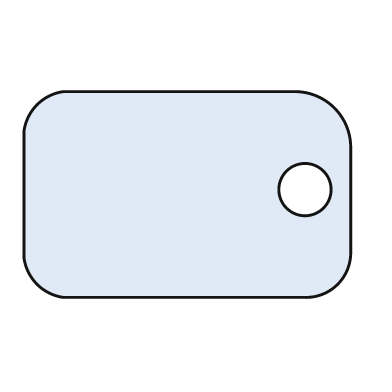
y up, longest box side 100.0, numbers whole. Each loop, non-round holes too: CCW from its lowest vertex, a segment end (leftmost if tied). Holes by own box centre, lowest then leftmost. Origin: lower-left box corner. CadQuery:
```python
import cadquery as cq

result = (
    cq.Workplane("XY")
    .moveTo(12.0, 0.0)
    .lineTo(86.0, 0.0)
    .threePointArc((96.0, 4.0), (100.0, 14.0))
    .lineTo(100.0, 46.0)
    .threePointArc((95.0, 58.0), (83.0, 63.0))
    .lineTo(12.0, 63.0)
    .threePointArc((4.0, 59.0), (0.0, 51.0))
    .lineTo(0.0, 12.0)
    .threePointArc((4.0, 4.0), (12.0, 0.0))
    .close()
    .moveTo(86.0, 33.0)
    .circle(8.0)
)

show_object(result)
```